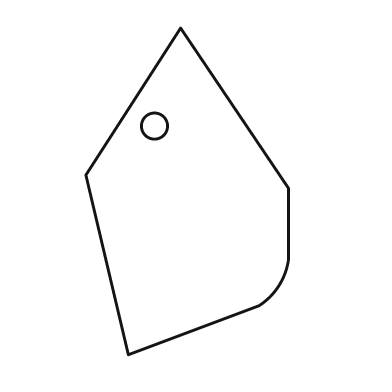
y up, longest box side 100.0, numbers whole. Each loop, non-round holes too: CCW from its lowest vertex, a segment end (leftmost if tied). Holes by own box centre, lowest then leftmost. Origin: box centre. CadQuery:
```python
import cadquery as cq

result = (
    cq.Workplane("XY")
    .moveTo(-18.0, -50.0)
    .lineTo(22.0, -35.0)
    .threePointArc((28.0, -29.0), (31.0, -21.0))
    .lineTo(31.0, 1.0)
    .lineTo(-2.0, 50.0)
    .lineTo(-31.0, 5.0)
    .close()
    .moveTo(-10.0, 20.0)
    .circle(4.0)
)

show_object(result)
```